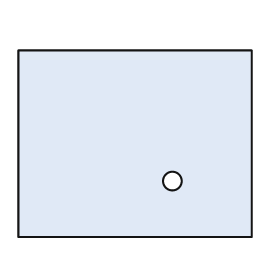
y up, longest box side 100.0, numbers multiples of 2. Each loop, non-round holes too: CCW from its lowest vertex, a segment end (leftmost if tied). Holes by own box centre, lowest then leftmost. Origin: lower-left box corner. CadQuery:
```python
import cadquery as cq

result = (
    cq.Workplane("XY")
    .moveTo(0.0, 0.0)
    .lineTo(100.0, 0.0)
    .lineTo(100.0, 80.0)
    .lineTo(0.0, 80.0)
    .close()
    .moveTo(66.0, 24.0)
    .circle(4.0)
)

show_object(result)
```